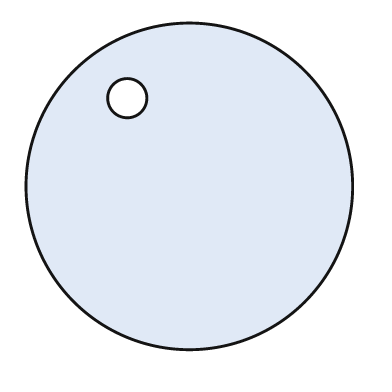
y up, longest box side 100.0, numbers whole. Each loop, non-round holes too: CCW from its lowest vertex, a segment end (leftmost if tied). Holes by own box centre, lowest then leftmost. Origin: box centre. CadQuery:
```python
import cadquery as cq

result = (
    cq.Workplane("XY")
    .moveTo(0.0, 0.0)
    .circle(50.0)
    .moveTo(-19.0, 27.0)
    .circle(6.0)
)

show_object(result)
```